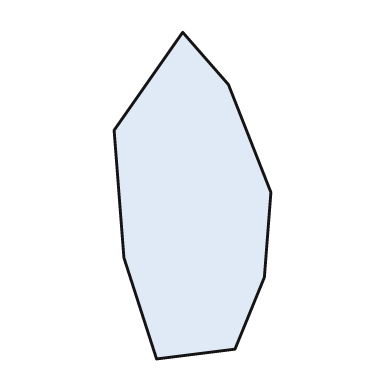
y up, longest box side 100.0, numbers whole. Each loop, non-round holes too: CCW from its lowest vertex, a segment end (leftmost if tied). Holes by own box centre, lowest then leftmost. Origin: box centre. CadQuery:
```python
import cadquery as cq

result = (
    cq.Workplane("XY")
    .moveTo(-11.0, -50.0)
    .lineTo(13.0, -47.0)
    .lineTo(22.0, -25.0)
    .lineTo(24.0, 1.0)
    .lineTo(11.0, 34.0)
    .lineTo(-3.0, 50.0)
    .lineTo(-24.0, 20.0)
    .lineTo(-21.0, -19.0)
    .close()
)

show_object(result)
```